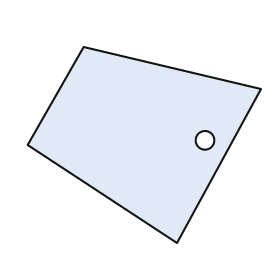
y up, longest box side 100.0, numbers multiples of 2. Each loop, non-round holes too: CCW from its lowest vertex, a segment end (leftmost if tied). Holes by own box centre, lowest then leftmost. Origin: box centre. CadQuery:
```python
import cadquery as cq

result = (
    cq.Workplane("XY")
    .moveTo(14.0, -42.0)
    .lineTo(50.0, 24.0)
    .lineTo(-26.0, 42.0)
    .lineTo(-50.0, 0.0)
    .close()
    .moveTo(26.0, 2.0)
    .circle(4.0)
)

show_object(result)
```